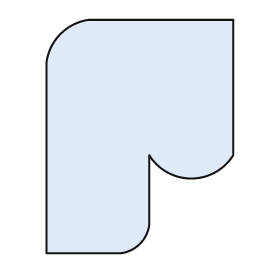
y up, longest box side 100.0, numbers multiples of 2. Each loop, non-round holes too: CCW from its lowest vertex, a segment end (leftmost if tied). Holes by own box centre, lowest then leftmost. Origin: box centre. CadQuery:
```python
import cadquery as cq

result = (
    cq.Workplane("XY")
    .moveTo(-40.0, -50.0)
    .lineTo(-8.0, -50.0)
    .threePointArc((0.0, -46.0), (4.0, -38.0))
    .lineTo(4.0, -8.0)
    .threePointArc((22.0, -18.0), (40.0, -8.0))
    .lineTo(40.0, 50.0)
    .lineTo(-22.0, 50.0)
    .threePointArc((-34.0, 44.0), (-40.0, 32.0))
    .close()
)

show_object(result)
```